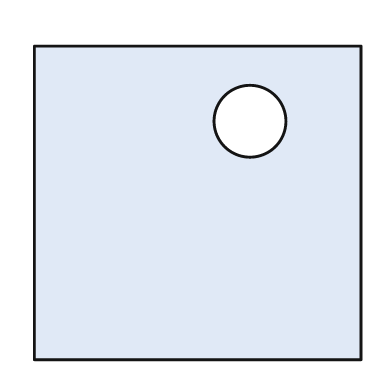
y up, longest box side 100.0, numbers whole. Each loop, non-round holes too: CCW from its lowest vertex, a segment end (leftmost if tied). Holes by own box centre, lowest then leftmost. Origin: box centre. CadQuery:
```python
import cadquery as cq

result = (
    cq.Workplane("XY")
    .moveTo(-50.0, -48.0)
    .lineTo(50.0, -48.0)
    .lineTo(50.0, 48.0)
    .lineTo(-50.0, 48.0)
    .close()
    .moveTo(16.0, 25.0)
    .circle(11.0)
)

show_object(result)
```